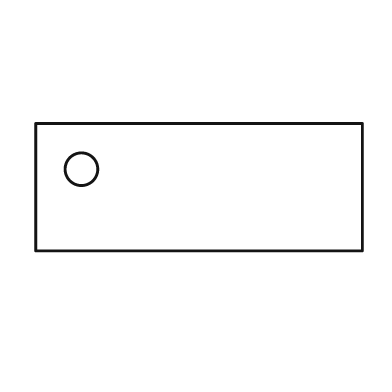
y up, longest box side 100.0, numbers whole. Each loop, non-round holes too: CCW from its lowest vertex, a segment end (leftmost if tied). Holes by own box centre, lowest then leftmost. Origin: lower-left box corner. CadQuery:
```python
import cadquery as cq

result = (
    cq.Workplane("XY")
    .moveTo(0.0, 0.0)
    .lineTo(100.0, 0.0)
    .lineTo(100.0, 39.0)
    .lineTo(0.0, 39.0)
    .close()
    .moveTo(14.0, 25.0)
    .circle(5.0)
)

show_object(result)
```